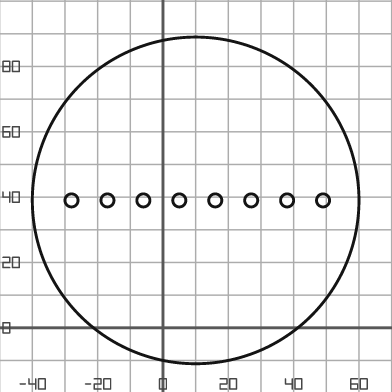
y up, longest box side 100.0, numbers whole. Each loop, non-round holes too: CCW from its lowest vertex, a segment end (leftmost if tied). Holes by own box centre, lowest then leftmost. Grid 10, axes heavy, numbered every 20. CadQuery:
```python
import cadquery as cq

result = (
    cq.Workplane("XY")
    .moveTo(10.0, 39.0)
    .circle(50.0)
    .moveTo(-28.0, 39.0)
    .circle(2.0)
    .moveTo(-17.0, 39.0)
    .circle(2.0)
    .moveTo(-6.0, 39.0)
    .circle(2.0)
    .moveTo(5.0, 39.0)
    .circle(2.0)
    .moveTo(16.0, 39.0)
    .circle(2.0)
    .moveTo(27.0, 39.0)
    .circle(2.0)
    .moveTo(38.0, 39.0)
    .circle(2.0)
    .moveTo(49.0, 39.0)
    .circle(2.0)
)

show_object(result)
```